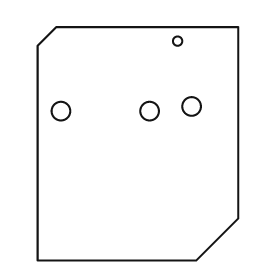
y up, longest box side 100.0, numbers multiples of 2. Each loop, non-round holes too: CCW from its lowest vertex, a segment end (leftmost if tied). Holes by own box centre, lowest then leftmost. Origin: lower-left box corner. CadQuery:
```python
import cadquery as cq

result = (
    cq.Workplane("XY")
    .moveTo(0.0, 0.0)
    .lineTo(68.0, 0.0)
    .lineTo(86.0, 18.0)
    .lineTo(86.0, 100.0)
    .lineTo(8.0, 100.0)
    .lineTo(0.0, 92.0)
    .close()
    .moveTo(10.0, 64.0)
    .circle(4.0)
    .moveTo(48.0, 64.0)
    .circle(4.0)
    .moveTo(66.0, 66.0)
    .circle(4.0)
    .moveTo(60.0, 94.0)
    .circle(2.0)
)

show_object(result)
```